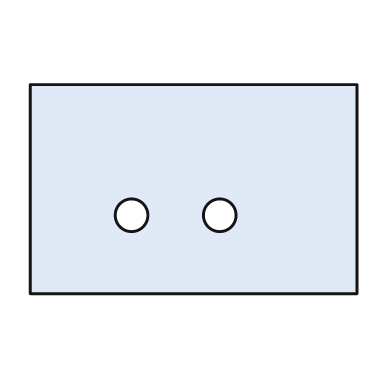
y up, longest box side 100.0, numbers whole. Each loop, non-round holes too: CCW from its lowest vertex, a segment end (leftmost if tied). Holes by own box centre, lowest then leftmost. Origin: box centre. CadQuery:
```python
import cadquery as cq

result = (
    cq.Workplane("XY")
    .moveTo(-50.0, -32.0)
    .lineTo(50.0, -32.0)
    .lineTo(50.0, 32.0)
    .lineTo(-50.0, 32.0)
    .close()
    .moveTo(-19.0, -8.0)
    .circle(5.0)
    .moveTo(8.0, -8.0)
    .circle(5.0)
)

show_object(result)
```